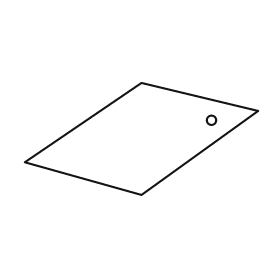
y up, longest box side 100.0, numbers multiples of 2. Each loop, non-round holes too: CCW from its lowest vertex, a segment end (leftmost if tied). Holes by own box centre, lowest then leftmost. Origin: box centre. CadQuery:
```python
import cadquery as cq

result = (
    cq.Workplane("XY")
    .moveTo(0.0, -24.0)
    .lineTo(50.0, 12.0)
    .lineTo(0.0, 24.0)
    .lineTo(-50.0, -10.0)
    .close()
    .moveTo(30.0, 8.0)
    .circle(2.0)
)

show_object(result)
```